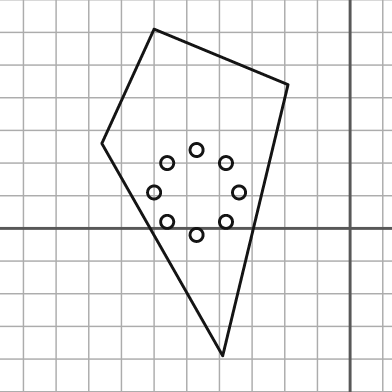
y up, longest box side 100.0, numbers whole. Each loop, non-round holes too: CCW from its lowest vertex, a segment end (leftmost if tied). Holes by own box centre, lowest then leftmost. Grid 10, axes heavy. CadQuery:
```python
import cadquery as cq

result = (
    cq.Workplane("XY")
    .moveTo(-39.0, -39.0)
    .lineTo(-19.0, 44.0)
    .lineTo(-60.0, 61.0)
    .lineTo(-76.0, 26.0)
    .close()
    .moveTo(-47.0, -2.0)
    .circle(2.0)
    .moveTo(-56.0, 2.0)
    .circle(2.0)
    .moveTo(-38.0, 2.0)
    .circle(2.0)
    .moveTo(-60.0, 11.0)
    .circle(2.0)
    .moveTo(-34.0, 11.0)
    .circle(2.0)
    .moveTo(-56.0, 20.0)
    .circle(2.0)
    .moveTo(-38.0, 20.0)
    .circle(2.0)
    .moveTo(-47.0, 24.0)
    .circle(2.0)
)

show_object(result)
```